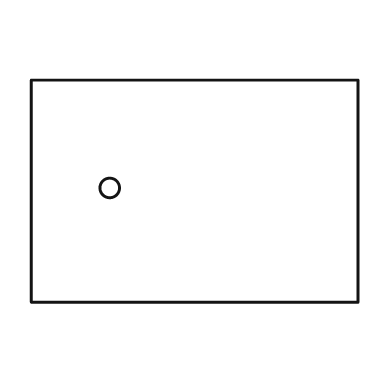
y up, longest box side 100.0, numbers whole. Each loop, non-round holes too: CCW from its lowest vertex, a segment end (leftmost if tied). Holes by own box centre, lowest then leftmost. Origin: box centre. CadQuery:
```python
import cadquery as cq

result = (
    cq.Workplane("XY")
    .moveTo(-50.0, -34.0)
    .lineTo(50.0, -34.0)
    .lineTo(50.0, 34.0)
    .lineTo(-50.0, 34.0)
    .close()
    .moveTo(-26.0, 1.0)
    .circle(3.0)
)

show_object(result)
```